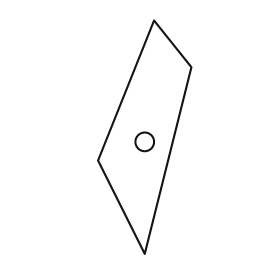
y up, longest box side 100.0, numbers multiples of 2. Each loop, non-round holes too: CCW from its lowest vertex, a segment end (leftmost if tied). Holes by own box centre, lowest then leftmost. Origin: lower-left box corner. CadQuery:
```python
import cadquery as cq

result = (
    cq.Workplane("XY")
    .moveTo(20.0, 0.0)
    .lineTo(40.0, 80.0)
    .lineTo(24.0, 100.0)
    .lineTo(0.0, 40.0)
    .close()
    .moveTo(20.0, 48.0)
    .circle(4.0)
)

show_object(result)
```